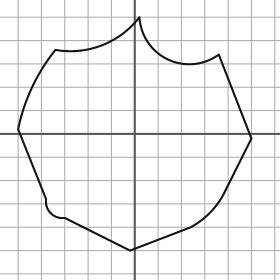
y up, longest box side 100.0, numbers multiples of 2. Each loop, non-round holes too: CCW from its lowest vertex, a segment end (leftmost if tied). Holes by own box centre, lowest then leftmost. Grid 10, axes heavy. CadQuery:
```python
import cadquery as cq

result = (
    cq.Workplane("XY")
    .moveTo(-2.0, -50.0)
    .lineTo(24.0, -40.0)
    .threePointArc((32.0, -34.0), (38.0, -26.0))
    .lineTo(50.0, -2.0)
    .lineTo(36.0, 34.0)
    .threePointArc((14.0, 32.0), (2.0, 50.0))
    .threePointArc((-14.0, 38.0), (-34.0, 36.0))
    .threePointArc((-44.0, 20.0), (-50.0, 2.0))
    .lineTo(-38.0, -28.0)
    .threePointArc((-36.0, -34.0), (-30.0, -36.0))
    .close()
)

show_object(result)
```